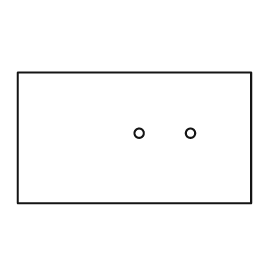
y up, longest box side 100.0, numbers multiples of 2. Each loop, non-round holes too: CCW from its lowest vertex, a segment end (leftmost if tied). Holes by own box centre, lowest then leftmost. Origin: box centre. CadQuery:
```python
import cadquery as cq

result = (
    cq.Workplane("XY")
    .moveTo(-50.0, -28.0)
    .lineTo(50.0, -28.0)
    .lineTo(50.0, 28.0)
    .lineTo(-50.0, 28.0)
    .close()
    .moveTo(2.0, 2.0)
    .circle(2.0)
    .moveTo(24.0, 2.0)
    .circle(2.0)
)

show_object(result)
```